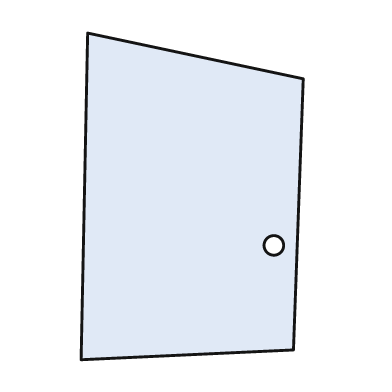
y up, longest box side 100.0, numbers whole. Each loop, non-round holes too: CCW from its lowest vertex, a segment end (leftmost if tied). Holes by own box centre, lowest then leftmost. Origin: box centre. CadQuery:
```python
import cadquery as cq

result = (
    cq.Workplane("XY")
    .moveTo(-34.0, -50.0)
    .lineTo(31.0, -47.0)
    .lineTo(34.0, 36.0)
    .lineTo(-32.0, 50.0)
    .close()
    .moveTo(25.0, -15.0)
    .circle(3.0)
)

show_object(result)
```